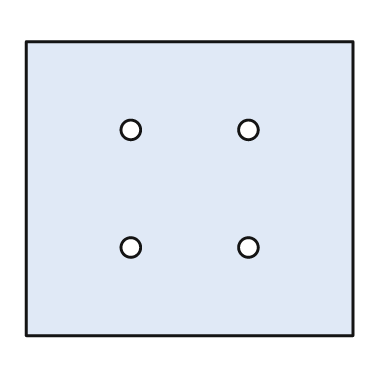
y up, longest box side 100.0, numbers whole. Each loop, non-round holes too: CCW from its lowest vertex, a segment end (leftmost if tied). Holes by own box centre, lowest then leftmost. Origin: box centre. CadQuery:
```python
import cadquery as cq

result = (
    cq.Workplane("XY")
    .moveTo(-50.0, -45.0)
    .lineTo(50.0, -45.0)
    .lineTo(50.0, 45.0)
    .lineTo(-50.0, 45.0)
    .close()
    .moveTo(-18.0, -18.0)
    .circle(3.0)
    .moveTo(18.0, -18.0)
    .circle(3.0)
    .moveTo(-18.0, 18.0)
    .circle(3.0)
    .moveTo(18.0, 18.0)
    .circle(3.0)
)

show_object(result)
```